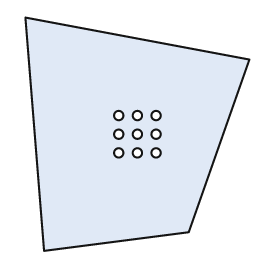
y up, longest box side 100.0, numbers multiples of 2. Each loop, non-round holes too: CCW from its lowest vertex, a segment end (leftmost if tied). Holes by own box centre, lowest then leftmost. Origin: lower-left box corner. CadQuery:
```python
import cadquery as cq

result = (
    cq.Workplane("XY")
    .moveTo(8.0, 0.0)
    .lineTo(70.0, 8.0)
    .lineTo(96.0, 82.0)
    .lineTo(0.0, 100.0)
    .close()
    .moveTo(40.0, 42.0)
    .circle(2.0)
    .moveTo(48.0, 42.0)
    .circle(2.0)
    .moveTo(56.0, 42.0)
    .circle(2.0)
    .moveTo(40.0, 50.0)
    .circle(2.0)
    .moveTo(48.0, 50.0)
    .circle(2.0)
    .moveTo(56.0, 50.0)
    .circle(2.0)
    .moveTo(40.0, 58.0)
    .circle(2.0)
    .moveTo(48.0, 58.0)
    .circle(2.0)
    .moveTo(56.0, 58.0)
    .circle(2.0)
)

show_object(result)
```